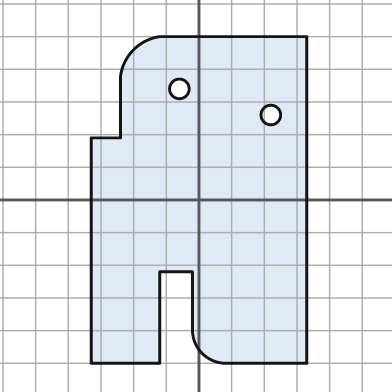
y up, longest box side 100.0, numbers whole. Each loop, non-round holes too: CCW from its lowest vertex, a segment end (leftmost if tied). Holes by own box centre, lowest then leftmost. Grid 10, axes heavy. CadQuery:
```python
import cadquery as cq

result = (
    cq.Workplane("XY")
    .moveTo(-33.0, -50.0)
    .lineTo(-12.0, -50.0)
    .lineTo(-12.0, -22.0)
    .lineTo(-2.0, -22.0)
    .lineTo(-2.0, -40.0)
    .threePointArc((1.0, -47.0), (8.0, -50.0))
    .lineTo(33.0, -50.0)
    .lineTo(33.0, 50.0)
    .lineTo(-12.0, 50.0)
    .threePointArc((-20.0, 46.0), (-24.0, 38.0))
    .lineTo(-24.0, 19.0)
    .lineTo(-33.0, 19.0)
    .close()
    .moveTo(22.0, 26.0)
    .circle(3.0)
    .moveTo(-6.0, 34.0)
    .circle(3.0)
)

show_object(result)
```